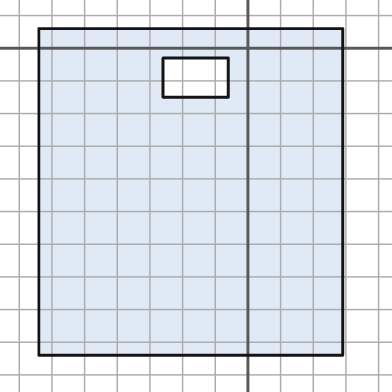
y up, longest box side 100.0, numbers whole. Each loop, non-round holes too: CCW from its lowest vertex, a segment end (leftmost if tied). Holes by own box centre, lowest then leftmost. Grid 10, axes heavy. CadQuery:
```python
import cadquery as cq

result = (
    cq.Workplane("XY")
    .moveTo(-64.0, -94.0)
    .lineTo(29.0, -94.0)
    .lineTo(29.0, 6.0)
    .lineTo(-64.0, 6.0)
    .close()
    .moveTo(-26.0, -15.0)
    .lineTo(-6.0, -15.0)
    .lineTo(-6.0, -3.0)
    .lineTo(-26.0, -3.0)
    .close()
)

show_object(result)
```